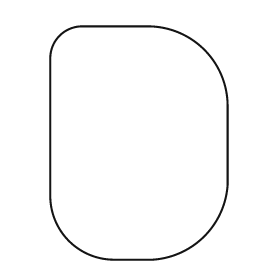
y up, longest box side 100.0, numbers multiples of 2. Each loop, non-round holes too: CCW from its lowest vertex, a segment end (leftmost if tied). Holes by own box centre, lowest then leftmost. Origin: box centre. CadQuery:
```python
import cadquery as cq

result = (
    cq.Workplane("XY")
    .moveTo(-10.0, -50.0)
    .lineTo(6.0, -50.0)
    .threePointArc((28.0, -40.0), (38.0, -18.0))
    .lineTo(38.0, 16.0)
    .threePointArc((28.0, 40.0), (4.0, 50.0))
    .lineTo(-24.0, 50.0)
    .threePointArc((-34.0, 46.0), (-38.0, 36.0))
    .lineTo(-38.0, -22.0)
    .threePointArc((-30.0, -42.0), (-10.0, -50.0))
    .close()
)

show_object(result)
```